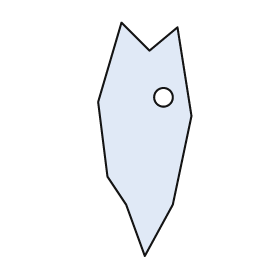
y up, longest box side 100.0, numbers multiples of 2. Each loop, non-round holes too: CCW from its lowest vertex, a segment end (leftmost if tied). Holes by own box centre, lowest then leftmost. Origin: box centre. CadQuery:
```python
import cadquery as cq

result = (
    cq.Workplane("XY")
    .moveTo(0.0, -50.0)
    .lineTo(12.0, -28.0)
    .lineTo(20.0, 10.0)
    .lineTo(14.0, 48.0)
    .lineTo(2.0, 38.0)
    .lineTo(-10.0, 50.0)
    .lineTo(-20.0, 16.0)
    .lineTo(-16.0, -16.0)
    .lineTo(-8.0, -28.0)
    .close()
    .moveTo(8.0, 18.0)
    .circle(4.0)
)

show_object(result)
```